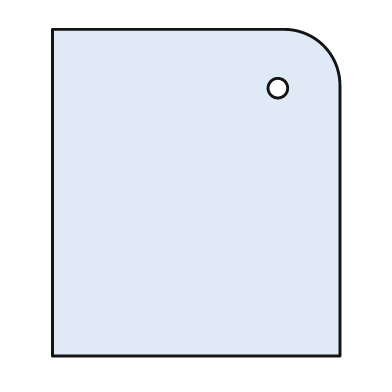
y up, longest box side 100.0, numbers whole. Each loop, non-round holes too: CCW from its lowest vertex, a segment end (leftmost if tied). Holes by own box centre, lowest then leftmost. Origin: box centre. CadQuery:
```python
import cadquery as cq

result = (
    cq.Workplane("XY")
    .moveTo(-44.0, -50.0)
    .lineTo(44.0, -50.0)
    .lineTo(44.0, 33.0)
    .threePointArc((39.0, 45.0), (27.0, 50.0))
    .lineTo(-44.0, 50.0)
    .close()
    .moveTo(25.0, 32.0)
    .circle(3.0)
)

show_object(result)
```